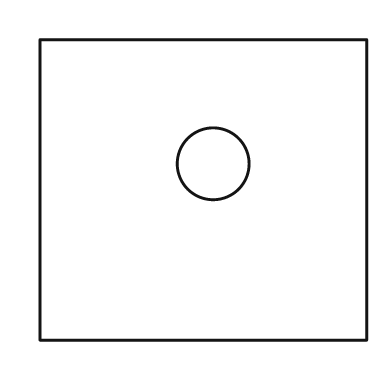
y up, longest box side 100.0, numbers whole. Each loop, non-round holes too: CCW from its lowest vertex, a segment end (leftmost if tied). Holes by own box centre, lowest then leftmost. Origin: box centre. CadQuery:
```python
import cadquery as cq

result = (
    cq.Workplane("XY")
    .moveTo(-50.0, -46.0)
    .lineTo(50.0, -46.0)
    .lineTo(50.0, 46.0)
    .lineTo(-50.0, 46.0)
    .close()
    .moveTo(3.0, 8.0)
    .circle(11.0)
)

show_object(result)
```